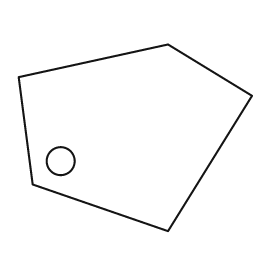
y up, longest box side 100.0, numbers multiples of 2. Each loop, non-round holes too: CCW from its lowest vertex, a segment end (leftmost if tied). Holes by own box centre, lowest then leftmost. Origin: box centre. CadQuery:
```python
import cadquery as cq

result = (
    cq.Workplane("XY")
    .moveTo(14.0, -40.0)
    .lineTo(50.0, 18.0)
    .lineTo(14.0, 40.0)
    .lineTo(-50.0, 26.0)
    .lineTo(-44.0, -20.0)
    .close()
    .moveTo(-32.0, -10.0)
    .circle(6.0)
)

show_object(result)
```